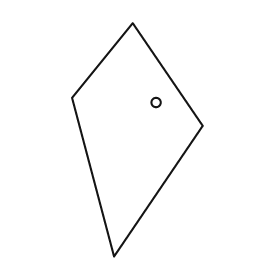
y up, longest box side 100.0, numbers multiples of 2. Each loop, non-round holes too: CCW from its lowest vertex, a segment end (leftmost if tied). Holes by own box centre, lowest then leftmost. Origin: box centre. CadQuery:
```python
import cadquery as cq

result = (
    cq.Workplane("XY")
    .moveTo(-10.0, -50.0)
    .lineTo(28.0, 6.0)
    .lineTo(-2.0, 50.0)
    .lineTo(-28.0, 18.0)
    .close()
    .moveTo(8.0, 16.0)
    .circle(2.0)
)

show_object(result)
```